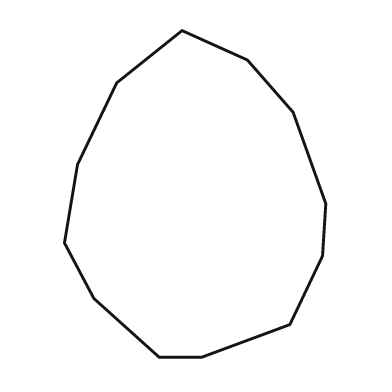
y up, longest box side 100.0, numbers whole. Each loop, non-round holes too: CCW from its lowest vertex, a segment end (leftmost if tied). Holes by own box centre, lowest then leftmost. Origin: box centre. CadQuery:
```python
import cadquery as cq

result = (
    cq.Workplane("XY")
    .moveTo(-11.0, -50.0)
    .lineTo(2.0, -50.0)
    .lineTo(29.0, -40.0)
    .lineTo(39.0, -19.0)
    .lineTo(40.0, -3.0)
    .lineTo(30.0, 25.0)
    .lineTo(16.0, 41.0)
    .lineTo(-4.0, 50.0)
    .lineTo(-24.0, 34.0)
    .lineTo(-36.0, 9.0)
    .lineTo(-40.0, -15.0)
    .lineTo(-31.0, -32.0)
    .close()
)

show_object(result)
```